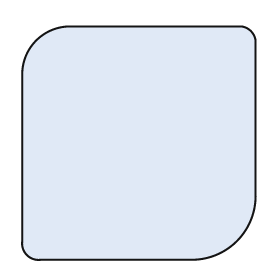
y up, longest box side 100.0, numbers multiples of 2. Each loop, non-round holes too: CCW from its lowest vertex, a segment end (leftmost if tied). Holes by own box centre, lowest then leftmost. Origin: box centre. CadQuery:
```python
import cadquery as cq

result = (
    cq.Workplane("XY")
    .moveTo(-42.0, -50.0)
    .lineTo(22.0, -50.0)
    .threePointArc((42.0, -42.0), (50.0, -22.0))
    .lineTo(50.0, 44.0)
    .threePointArc((48.0, 48.0), (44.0, 50.0))
    .lineTo(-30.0, 50.0)
    .threePointArc((-44.0, 44.0), (-50.0, 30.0))
    .lineTo(-50.0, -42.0)
    .threePointArc((-48.0, -48.0), (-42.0, -50.0))
    .close()
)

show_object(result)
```